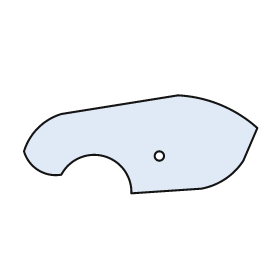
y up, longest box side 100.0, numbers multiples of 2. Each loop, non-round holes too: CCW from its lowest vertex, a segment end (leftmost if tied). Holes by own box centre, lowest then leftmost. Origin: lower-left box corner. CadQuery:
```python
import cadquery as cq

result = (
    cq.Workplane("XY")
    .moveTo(46.0, 0.0)
    .lineTo(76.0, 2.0)
    .threePointArc((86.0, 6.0), (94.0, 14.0))
    .lineTo(100.0, 28.0)
    .threePointArc((84.0, 38.0), (66.0, 42.0))
    .lineTo(16.0, 34.0)
    .threePointArc((6.0, 28.0), (0.0, 18.0))
    .threePointArc((6.0, 10.0), (16.0, 8.0))
    .threePointArc((34.0, 16.0), (46.0, 0.0))
    .close()
    .moveTo(58.0, 16.0)
    .circle(2.0)
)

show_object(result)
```